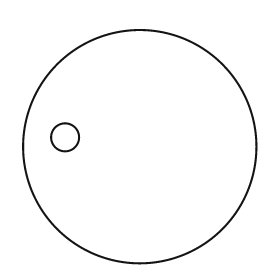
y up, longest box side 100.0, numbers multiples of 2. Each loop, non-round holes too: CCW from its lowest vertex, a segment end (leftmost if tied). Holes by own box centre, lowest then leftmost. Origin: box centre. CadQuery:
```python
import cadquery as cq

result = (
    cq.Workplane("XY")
    .moveTo(0.0, 0.0)
    .circle(50.0)
    .moveTo(-32.0, 4.0)
    .circle(6.0)
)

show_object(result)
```